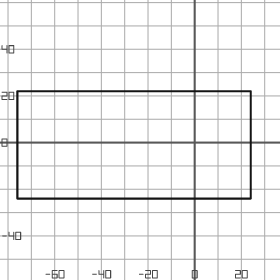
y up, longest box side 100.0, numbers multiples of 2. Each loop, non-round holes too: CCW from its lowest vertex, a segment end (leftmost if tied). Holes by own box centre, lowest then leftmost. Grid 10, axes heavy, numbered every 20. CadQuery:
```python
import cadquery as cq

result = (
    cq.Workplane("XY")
    .moveTo(-76.0, -24.0)
    .lineTo(24.0, -24.0)
    .lineTo(24.0, 22.0)
    .lineTo(-76.0, 22.0)
    .close()
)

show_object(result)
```